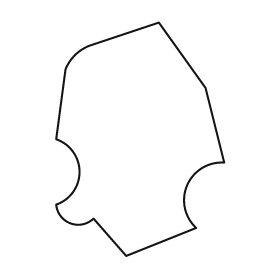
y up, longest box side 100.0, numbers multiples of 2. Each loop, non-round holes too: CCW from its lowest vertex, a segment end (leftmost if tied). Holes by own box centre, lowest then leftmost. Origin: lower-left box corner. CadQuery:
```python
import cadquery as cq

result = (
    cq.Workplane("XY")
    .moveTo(30.0, 0.0)
    .lineTo(60.0, 12.0)
    .threePointArc((56.0, 30.0), (72.0, 40.0))
    .lineTo(64.0, 72.0)
    .lineTo(44.0, 100.0)
    .lineTo(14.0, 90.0)
    .threePointArc((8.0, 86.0), (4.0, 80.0))
    .lineTo(0.0, 50.0)
    .threePointArc((10.0, 36.0), (0.0, 22.0))
    .threePointArc((6.0, 14.0), (16.0, 16.0))
    .close()
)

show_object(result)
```